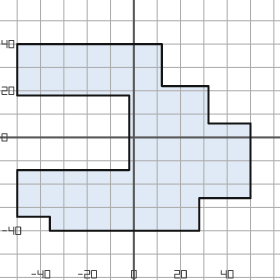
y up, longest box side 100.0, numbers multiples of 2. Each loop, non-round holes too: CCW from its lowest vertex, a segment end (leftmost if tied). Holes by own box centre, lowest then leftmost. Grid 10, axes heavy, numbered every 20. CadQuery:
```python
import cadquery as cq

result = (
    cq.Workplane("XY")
    .moveTo(-36.0, -40.0)
    .lineTo(28.0, -40.0)
    .lineTo(28.0, -26.0)
    .lineTo(50.0, -26.0)
    .lineTo(50.0, 6.0)
    .lineTo(32.0, 6.0)
    .lineTo(32.0, 22.0)
    .lineTo(12.0, 22.0)
    .lineTo(12.0, 40.0)
    .lineTo(-50.0, 40.0)
    .lineTo(-50.0, 18.0)
    .lineTo(-2.0, 18.0)
    .lineTo(-2.0, -14.0)
    .lineTo(-50.0, -14.0)
    .lineTo(-50.0, -34.0)
    .lineTo(-36.0, -34.0)
    .close()
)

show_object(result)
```